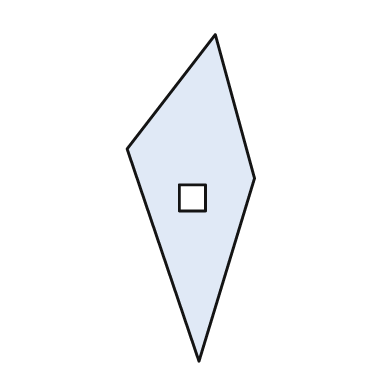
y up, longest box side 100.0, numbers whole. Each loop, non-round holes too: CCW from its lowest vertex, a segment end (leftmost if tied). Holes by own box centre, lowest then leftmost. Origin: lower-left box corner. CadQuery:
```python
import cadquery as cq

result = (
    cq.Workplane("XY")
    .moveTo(22.0, 0.0)
    .lineTo(39.0, 56.0)
    .lineTo(27.0, 100.0)
    .lineTo(0.0, 65.0)
    .close()
    .moveTo(16.0, 46.0)
    .lineTo(24.0, 46.0)
    .lineTo(24.0, 54.0)
    .lineTo(16.0, 54.0)
    .close()
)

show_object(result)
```